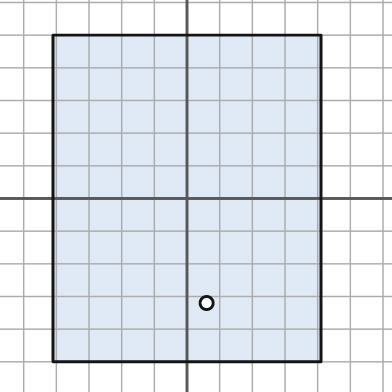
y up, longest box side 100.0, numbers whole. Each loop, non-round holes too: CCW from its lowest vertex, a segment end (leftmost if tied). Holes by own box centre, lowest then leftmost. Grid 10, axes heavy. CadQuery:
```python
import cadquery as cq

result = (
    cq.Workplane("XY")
    .moveTo(-41.0, -50.0)
    .lineTo(41.0, -50.0)
    .lineTo(41.0, 50.0)
    .lineTo(-41.0, 50.0)
    .close()
    .moveTo(6.0, -32.0)
    .circle(2.0)
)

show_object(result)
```